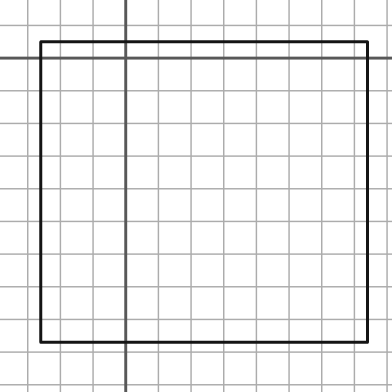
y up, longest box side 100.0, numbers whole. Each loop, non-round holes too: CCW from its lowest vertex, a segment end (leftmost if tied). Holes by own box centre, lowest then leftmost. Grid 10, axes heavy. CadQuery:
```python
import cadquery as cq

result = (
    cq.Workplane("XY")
    .moveTo(-26.0, -87.0)
    .lineTo(74.0, -87.0)
    .lineTo(74.0, 5.0)
    .lineTo(-26.0, 5.0)
    .close()
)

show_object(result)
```